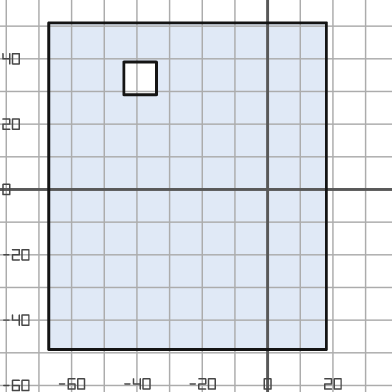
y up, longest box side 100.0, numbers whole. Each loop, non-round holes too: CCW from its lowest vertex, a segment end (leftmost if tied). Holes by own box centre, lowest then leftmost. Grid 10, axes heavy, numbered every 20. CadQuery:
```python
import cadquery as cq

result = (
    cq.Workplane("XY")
    .moveTo(-67.0, -49.0)
    .lineTo(18.0, -49.0)
    .lineTo(18.0, 51.0)
    .lineTo(-67.0, 51.0)
    .close()
    .moveTo(-44.0, 29.0)
    .lineTo(-34.0, 29.0)
    .lineTo(-34.0, 39.0)
    .lineTo(-44.0, 39.0)
    .close()
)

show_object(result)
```